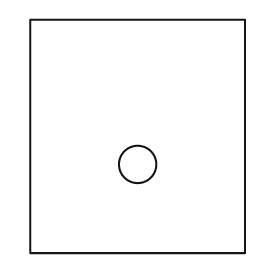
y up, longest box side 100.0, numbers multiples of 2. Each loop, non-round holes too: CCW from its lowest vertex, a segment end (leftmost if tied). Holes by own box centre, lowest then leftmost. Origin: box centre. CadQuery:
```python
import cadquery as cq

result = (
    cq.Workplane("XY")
    .moveTo(-46.0, -50.0)
    .lineTo(46.0, -50.0)
    .lineTo(46.0, 50.0)
    .lineTo(-46.0, 50.0)
    .close()
    .moveTo(0.0, -12.0)
    .circle(8.0)
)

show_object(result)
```